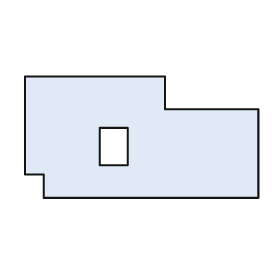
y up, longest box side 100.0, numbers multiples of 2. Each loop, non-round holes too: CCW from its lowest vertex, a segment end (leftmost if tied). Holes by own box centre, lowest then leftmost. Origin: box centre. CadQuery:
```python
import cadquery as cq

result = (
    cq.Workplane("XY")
    .moveTo(-42.0, -26.0)
    .lineTo(50.0, -26.0)
    .lineTo(50.0, 12.0)
    .lineTo(10.0, 12.0)
    .lineTo(10.0, 26.0)
    .lineTo(-50.0, 26.0)
    .lineTo(-50.0, -16.0)
    .lineTo(-42.0, -16.0)
    .close()
    .moveTo(-18.0, -12.0)
    .lineTo(-6.0, -12.0)
    .lineTo(-6.0, 4.0)
    .lineTo(-18.0, 4.0)
    .close()
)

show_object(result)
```